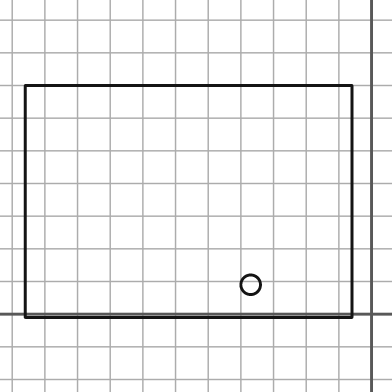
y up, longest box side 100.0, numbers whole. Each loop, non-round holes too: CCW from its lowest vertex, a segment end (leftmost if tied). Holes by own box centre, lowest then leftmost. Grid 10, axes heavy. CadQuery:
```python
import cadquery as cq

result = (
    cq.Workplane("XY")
    .moveTo(-106.0, -1.0)
    .lineTo(-6.0, -1.0)
    .lineTo(-6.0, 70.0)
    .lineTo(-106.0, 70.0)
    .close()
    .moveTo(-37.0, 9.0)
    .circle(3.0)
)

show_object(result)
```